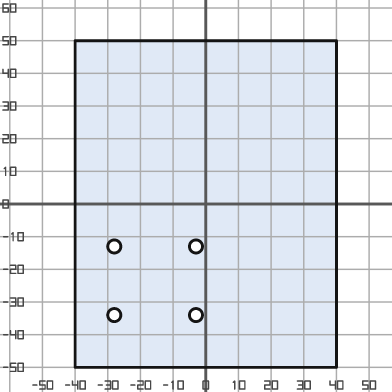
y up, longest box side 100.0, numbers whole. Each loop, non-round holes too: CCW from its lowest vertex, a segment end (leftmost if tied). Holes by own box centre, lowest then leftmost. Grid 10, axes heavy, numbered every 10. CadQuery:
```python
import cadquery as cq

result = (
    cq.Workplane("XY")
    .moveTo(-40.0, -50.0)
    .lineTo(40.0, -50.0)
    .lineTo(40.0, 50.0)
    .lineTo(-40.0, 50.0)
    .close()
    .moveTo(-28.0, -34.0)
    .circle(2.0)
    .moveTo(-3.0, -34.0)
    .circle(2.0)
    .moveTo(-28.0, -13.0)
    .circle(2.0)
    .moveTo(-3.0, -13.0)
    .circle(2.0)
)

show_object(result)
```